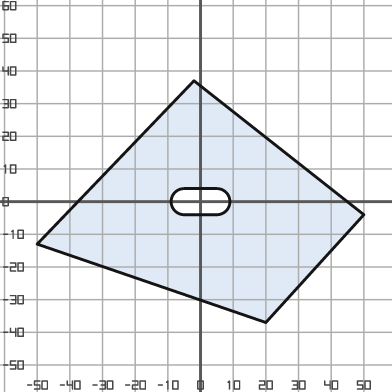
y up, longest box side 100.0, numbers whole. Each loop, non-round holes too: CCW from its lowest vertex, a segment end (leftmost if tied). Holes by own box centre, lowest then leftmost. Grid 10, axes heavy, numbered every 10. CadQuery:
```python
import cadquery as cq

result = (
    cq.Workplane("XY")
    .moveTo(20.0, -37.0)
    .lineTo(50.0, -4.0)
    .lineTo(-2.0, 37.0)
    .lineTo(-50.0, -13.0)
    .close()
    .moveTo(-5.0, -4.0)
    .lineTo(5.0, -4.0)
    .threePointArc((9.0, 0.0), (5.0, 4.0))
    .lineTo(-5.0, 4.0)
    .threePointArc((-9.0, 0.0), (-5.0, -4.0))
    .close()
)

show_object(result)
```